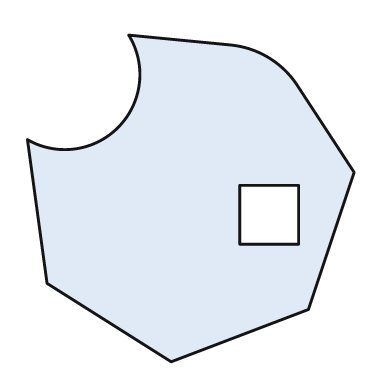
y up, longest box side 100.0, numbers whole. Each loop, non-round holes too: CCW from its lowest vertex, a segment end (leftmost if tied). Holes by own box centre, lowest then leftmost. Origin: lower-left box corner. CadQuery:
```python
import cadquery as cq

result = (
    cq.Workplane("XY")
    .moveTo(44.0, 0.0)
    .lineTo(86.0, 16.0)
    .lineTo(100.0, 58.0)
    .lineTo(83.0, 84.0)
    .threePointArc((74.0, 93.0), (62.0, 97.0))
    .lineTo(31.0, 100.0)
    .threePointArc((28.0, 72.0), (0.0, 68.0))
    .lineTo(6.0, 24.0)
    .close()
    .moveTo(65.0, 36.0)
    .lineTo(83.0, 36.0)
    .lineTo(83.0, 54.0)
    .lineTo(65.0, 54.0)
    .close()
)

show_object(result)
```